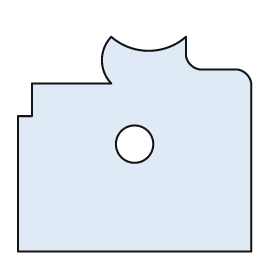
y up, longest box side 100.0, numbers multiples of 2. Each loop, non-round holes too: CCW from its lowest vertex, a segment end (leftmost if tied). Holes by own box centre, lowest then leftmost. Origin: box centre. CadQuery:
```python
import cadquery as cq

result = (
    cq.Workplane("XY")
    .moveTo(-50.0, -46.0)
    .lineTo(50.0, -46.0)
    .lineTo(50.0, 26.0)
    .threePointArc((48.0, 30.0), (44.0, 32.0))
    .lineTo(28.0, 32.0)
    .threePointArc((24.0, 34.0), (22.0, 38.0))
    .lineTo(22.0, 46.0)
    .threePointArc((6.0, 40.0), (-10.0, 46.0))
    .threePointArc((-14.0, 36.0), (-10.0, 26.0))
    .lineTo(-44.0, 26.0)
    .lineTo(-44.0, 12.0)
    .lineTo(-50.0, 12.0)
    .close()
    .moveTo(0.0, 0.0)
    .circle(8.0)
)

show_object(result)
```